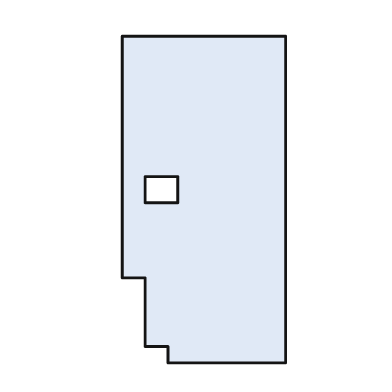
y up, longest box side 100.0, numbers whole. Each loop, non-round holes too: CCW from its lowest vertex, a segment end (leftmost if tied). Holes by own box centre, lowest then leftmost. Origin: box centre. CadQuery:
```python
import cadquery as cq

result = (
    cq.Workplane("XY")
    .moveTo(-11.0, -50.0)
    .lineTo(25.0, -50.0)
    .lineTo(25.0, 50.0)
    .lineTo(-25.0, 50.0)
    .lineTo(-25.0, -24.0)
    .lineTo(-18.0, -24.0)
    .lineTo(-18.0, -45.0)
    .lineTo(-11.0, -45.0)
    .close()
    .moveTo(-18.0, -1.0)
    .lineTo(-8.0, -1.0)
    .lineTo(-8.0, 7.0)
    .lineTo(-18.0, 7.0)
    .close()
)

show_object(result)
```